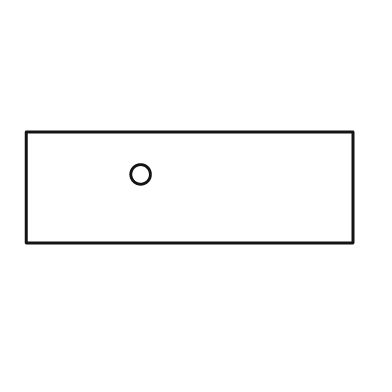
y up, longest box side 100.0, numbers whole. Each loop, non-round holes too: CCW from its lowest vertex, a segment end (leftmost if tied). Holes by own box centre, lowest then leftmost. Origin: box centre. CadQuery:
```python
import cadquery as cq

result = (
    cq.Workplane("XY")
    .moveTo(-50.0, -17.0)
    .lineTo(50.0, -17.0)
    .lineTo(50.0, 17.0)
    .lineTo(-50.0, 17.0)
    .close()
    .moveTo(-15.0, 4.0)
    .circle(3.0)
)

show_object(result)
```